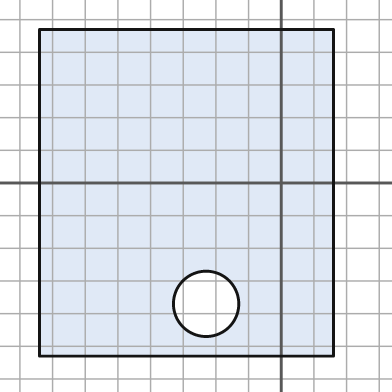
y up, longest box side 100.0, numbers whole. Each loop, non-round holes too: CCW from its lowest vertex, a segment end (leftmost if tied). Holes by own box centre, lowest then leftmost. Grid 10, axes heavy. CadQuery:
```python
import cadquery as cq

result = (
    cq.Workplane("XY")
    .moveTo(-74.0, -53.0)
    .lineTo(16.0, -53.0)
    .lineTo(16.0, 47.0)
    .lineTo(-74.0, 47.0)
    .close()
    .moveTo(-23.0, -37.0)
    .circle(10.0)
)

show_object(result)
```